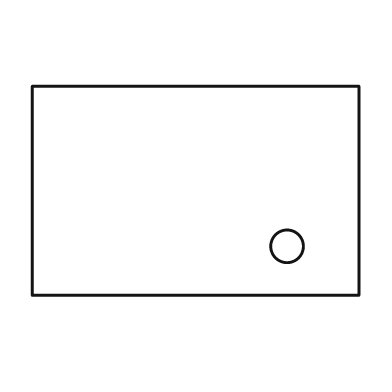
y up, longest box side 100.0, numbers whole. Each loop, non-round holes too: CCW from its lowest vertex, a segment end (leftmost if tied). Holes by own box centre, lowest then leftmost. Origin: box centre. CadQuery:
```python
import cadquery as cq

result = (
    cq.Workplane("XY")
    .moveTo(-50.0, -32.0)
    .lineTo(50.0, -32.0)
    .lineTo(50.0, 32.0)
    .lineTo(-50.0, 32.0)
    .close()
    .moveTo(28.0, -17.0)
    .circle(5.0)
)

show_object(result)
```